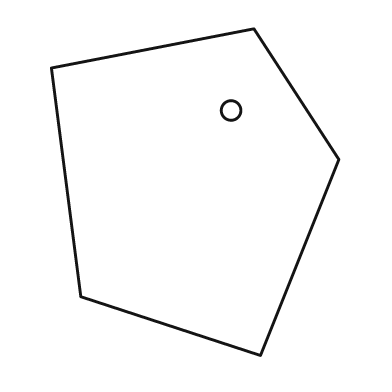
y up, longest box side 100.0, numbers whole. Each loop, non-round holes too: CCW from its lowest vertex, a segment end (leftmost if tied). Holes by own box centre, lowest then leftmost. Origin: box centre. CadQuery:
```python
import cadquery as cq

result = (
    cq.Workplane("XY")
    .moveTo(20.0, -50.0)
    .lineTo(44.0, 10.0)
    .lineTo(18.0, 50.0)
    .lineTo(-44.0, 38.0)
    .lineTo(-35.0, -32.0)
    .close()
    .moveTo(11.0, 25.0)
    .circle(3.0)
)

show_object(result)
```